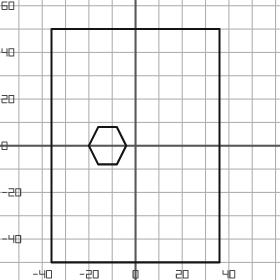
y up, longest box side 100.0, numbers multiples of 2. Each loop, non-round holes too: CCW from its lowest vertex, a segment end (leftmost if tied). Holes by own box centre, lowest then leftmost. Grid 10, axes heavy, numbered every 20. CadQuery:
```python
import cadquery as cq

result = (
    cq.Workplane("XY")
    .moveTo(-36.0, -50.0)
    .lineTo(36.0, -50.0)
    .lineTo(36.0, 50.0)
    .lineTo(-36.0, 50.0)
    .close()
    .moveTo(-16.0, -8.0)
    .lineTo(-8.0, -8.0)
    .lineTo(-4.0, 0.0)
    .lineTo(-8.0, 8.0)
    .lineTo(-16.0, 8.0)
    .lineTo(-20.0, 0.0)
    .close()
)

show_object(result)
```